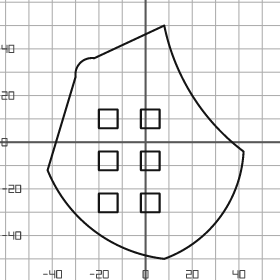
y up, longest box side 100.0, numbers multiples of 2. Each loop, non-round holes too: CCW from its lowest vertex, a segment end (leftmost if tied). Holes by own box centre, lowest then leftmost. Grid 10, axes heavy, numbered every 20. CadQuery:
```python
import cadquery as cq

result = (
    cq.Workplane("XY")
    .moveTo(8.0, -50.0)
    .threePointArc((32.0, -32.0), (42.0, -4.0))
    .threePointArc((20.0, 20.0), (8.0, 50.0))
    .lineTo(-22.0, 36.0)
    .threePointArc((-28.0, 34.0), (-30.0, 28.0))
    .lineTo(-42.0, -12.0)
    .threePointArc((-22.0, -38.0), (8.0, -50.0))
    .close()
    .moveTo(-20.0, -30.0)
    .lineTo(-12.0, -30.0)
    .lineTo(-12.0, -22.0)
    .lineTo(-20.0, -22.0)
    .close()
    .moveTo(-2.0, -30.0)
    .lineTo(6.0, -30.0)
    .lineTo(6.0, -22.0)
    .lineTo(-2.0, -22.0)
    .close()
    .moveTo(-20.0, -12.0)
    .lineTo(-12.0, -12.0)
    .lineTo(-12.0, -4.0)
    .lineTo(-20.0, -4.0)
    .close()
    .moveTo(-2.0, -12.0)
    .lineTo(6.0, -12.0)
    .lineTo(6.0, -4.0)
    .lineTo(-2.0, -4.0)
    .close()
    .moveTo(-20.0, 6.0)
    .lineTo(-12.0, 6.0)
    .lineTo(-12.0, 14.0)
    .lineTo(-20.0, 14.0)
    .close()
    .moveTo(-2.0, 6.0)
    .lineTo(6.0, 6.0)
    .lineTo(6.0, 14.0)
    .lineTo(-2.0, 14.0)
    .close()
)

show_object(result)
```